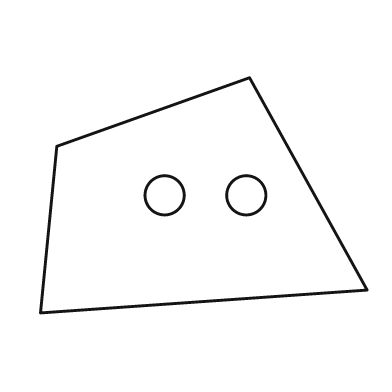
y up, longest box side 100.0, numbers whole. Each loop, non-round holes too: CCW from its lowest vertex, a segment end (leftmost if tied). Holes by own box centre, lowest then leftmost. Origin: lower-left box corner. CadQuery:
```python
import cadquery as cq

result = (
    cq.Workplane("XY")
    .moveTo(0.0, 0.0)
    .lineTo(100.0, 7.0)
    .lineTo(64.0, 72.0)
    .lineTo(5.0, 51.0)
    .close()
    .moveTo(38.0, 36.0)
    .circle(6.0)
    .moveTo(63.0, 36.0)
    .circle(6.0)
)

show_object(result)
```